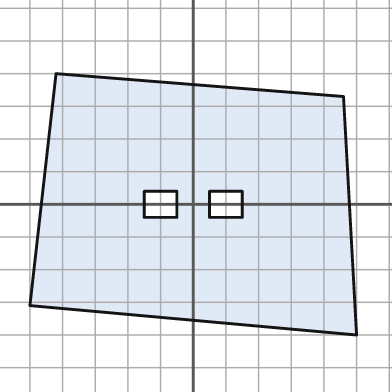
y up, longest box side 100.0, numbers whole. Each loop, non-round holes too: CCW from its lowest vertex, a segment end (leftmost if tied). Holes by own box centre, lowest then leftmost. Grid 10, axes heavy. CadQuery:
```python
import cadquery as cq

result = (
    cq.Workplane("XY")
    .moveTo(50.0, -40.0)
    .lineTo(46.0, 33.0)
    .lineTo(-42.0, 40.0)
    .lineTo(-50.0, -31.0)
    .close()
    .moveTo(-15.0, -4.0)
    .lineTo(-5.0, -4.0)
    .lineTo(-5.0, 4.0)
    .lineTo(-15.0, 4.0)
    .close()
    .moveTo(5.0, -4.0)
    .lineTo(15.0, -4.0)
    .lineTo(15.0, 4.0)
    .lineTo(5.0, 4.0)
    .close()
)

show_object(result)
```